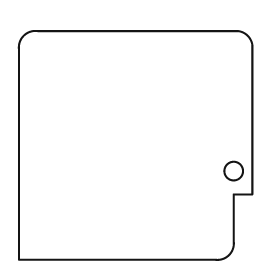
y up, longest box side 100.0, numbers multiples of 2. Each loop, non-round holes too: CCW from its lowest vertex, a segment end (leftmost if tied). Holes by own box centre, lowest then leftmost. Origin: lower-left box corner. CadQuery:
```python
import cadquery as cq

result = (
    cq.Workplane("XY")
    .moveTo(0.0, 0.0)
    .lineTo(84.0, 0.0)
    .threePointArc((90.0, 2.0), (92.0, 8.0))
    .lineTo(92.0, 28.0)
    .lineTo(100.0, 28.0)
    .lineTo(100.0, 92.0)
    .threePointArc((98.0, 96.0), (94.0, 98.0))
    .lineTo(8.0, 98.0)
    .threePointArc((2.0, 96.0), (0.0, 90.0))
    .close()
    .moveTo(92.0, 38.0)
    .circle(4.0)
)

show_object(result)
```